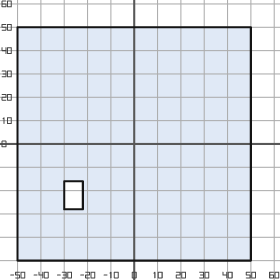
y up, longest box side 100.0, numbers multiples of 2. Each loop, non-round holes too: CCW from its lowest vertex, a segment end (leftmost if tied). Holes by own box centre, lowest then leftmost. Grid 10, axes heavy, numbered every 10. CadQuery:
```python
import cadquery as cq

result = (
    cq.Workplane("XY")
    .moveTo(-50.0, -50.0)
    .lineTo(50.0, -50.0)
    .lineTo(50.0, 50.0)
    .lineTo(-50.0, 50.0)
    .close()
    .moveTo(-30.0, -28.0)
    .lineTo(-22.0, -28.0)
    .lineTo(-22.0, -16.0)
    .lineTo(-30.0, -16.0)
    .close()
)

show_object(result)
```